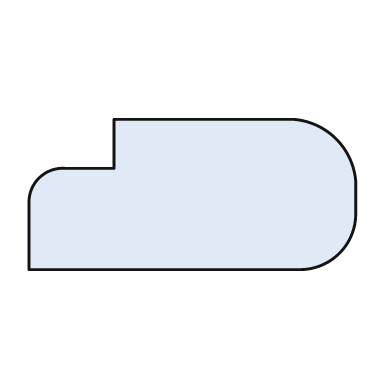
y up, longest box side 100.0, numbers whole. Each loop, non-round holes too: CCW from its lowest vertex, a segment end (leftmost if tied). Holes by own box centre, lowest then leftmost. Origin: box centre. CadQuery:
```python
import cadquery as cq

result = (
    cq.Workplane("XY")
    .moveTo(-50.0, -23.0)
    .lineTo(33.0, -23.0)
    .threePointArc((45.0, -18.0), (50.0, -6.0))
    .lineTo(50.0, 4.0)
    .threePointArc((44.0, 17.0), (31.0, 23.0))
    .lineTo(-24.0, 23.0)
    .lineTo(-24.0, 8.0)
    .lineTo(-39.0, 8.0)
    .threePointArc((-47.0, 5.0), (-50.0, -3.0))
    .close()
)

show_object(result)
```